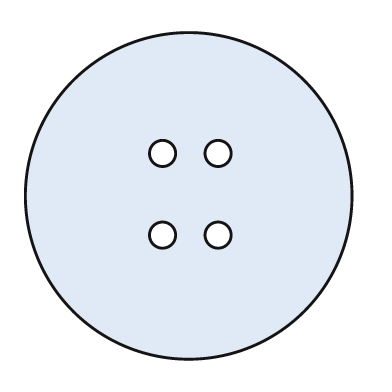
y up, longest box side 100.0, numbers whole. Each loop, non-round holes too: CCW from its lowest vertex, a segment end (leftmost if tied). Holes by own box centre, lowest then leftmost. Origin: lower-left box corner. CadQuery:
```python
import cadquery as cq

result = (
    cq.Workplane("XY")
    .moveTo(50.0, 50.0)
    .circle(50.0)
    .moveTo(42.0, 38.0)
    .circle(4.0)
    .moveTo(59.0, 38.0)
    .circle(4.0)
    .moveTo(42.0, 63.0)
    .circle(4.0)
    .moveTo(59.0, 63.0)
    .circle(4.0)
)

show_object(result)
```